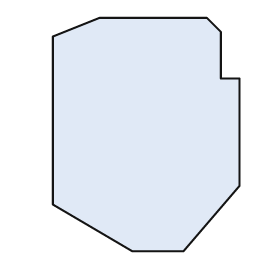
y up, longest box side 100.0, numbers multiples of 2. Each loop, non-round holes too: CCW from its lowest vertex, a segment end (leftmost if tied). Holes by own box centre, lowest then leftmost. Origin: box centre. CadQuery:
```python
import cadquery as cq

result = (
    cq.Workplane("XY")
    .moveTo(-6.0, -50.0)
    .lineTo(16.0, -50.0)
    .lineTo(40.0, -22.0)
    .lineTo(40.0, 24.0)
    .lineTo(32.0, 24.0)
    .lineTo(32.0, 44.0)
    .lineTo(26.0, 50.0)
    .lineTo(-20.0, 50.0)
    .lineTo(-40.0, 42.0)
    .lineTo(-40.0, -30.0)
    .close()
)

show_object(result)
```